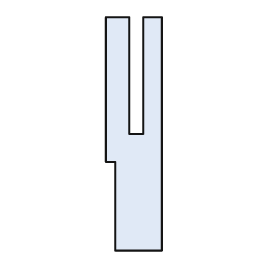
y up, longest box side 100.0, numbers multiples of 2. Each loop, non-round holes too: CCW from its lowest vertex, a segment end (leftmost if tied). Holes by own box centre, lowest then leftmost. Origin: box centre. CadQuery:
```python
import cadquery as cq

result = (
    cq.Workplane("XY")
    .moveTo(-8.0, -50.0)
    .lineTo(12.0, -50.0)
    .lineTo(12.0, 50.0)
    .lineTo(4.0, 50.0)
    .lineTo(4.0, 0.0)
    .lineTo(-2.0, 0.0)
    .lineTo(-2.0, 50.0)
    .lineTo(-12.0, 50.0)
    .lineTo(-12.0, -12.0)
    .lineTo(-8.0, -12.0)
    .close()
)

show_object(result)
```